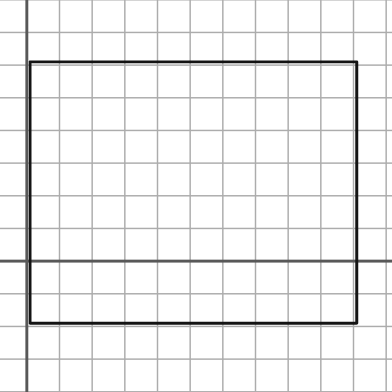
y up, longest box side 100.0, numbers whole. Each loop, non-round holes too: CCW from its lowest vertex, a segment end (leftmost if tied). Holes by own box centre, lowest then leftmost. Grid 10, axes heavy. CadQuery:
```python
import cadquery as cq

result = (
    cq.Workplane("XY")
    .moveTo(1.0, -19.0)
    .lineTo(101.0, -19.0)
    .lineTo(101.0, 61.0)
    .lineTo(1.0, 61.0)
    .close()
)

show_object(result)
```